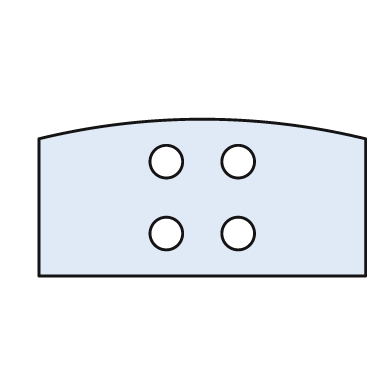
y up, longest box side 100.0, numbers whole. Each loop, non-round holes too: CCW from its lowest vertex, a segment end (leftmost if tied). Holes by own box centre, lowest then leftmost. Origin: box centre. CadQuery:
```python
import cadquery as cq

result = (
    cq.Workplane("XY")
    .moveTo(-50.0, -24.0)
    .lineTo(50.0, -24.0)
    .lineTo(50.0, 18.0)
    .threePointArc((0.0, 24.0), (-50.0, 18.0))
    .close()
    .moveTo(-11.0, -11.0)
    .circle(5.0)
    .moveTo(11.0, -11.0)
    .circle(5.0)
    .moveTo(-11.0, 11.0)
    .circle(5.0)
    .moveTo(11.0, 11.0)
    .circle(5.0)
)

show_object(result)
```